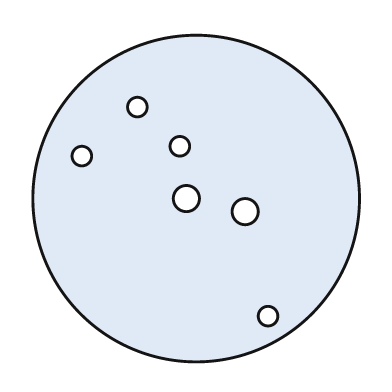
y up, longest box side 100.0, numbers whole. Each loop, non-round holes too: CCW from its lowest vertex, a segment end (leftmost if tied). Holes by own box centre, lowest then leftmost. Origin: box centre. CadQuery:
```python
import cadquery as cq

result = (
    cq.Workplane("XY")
    .moveTo(0.0, 0.0)
    .circle(50.0)
    .moveTo(22.0, -36.0)
    .circle(3.0)
    .moveTo(15.0, -4.0)
    .circle(4.0)
    .moveTo(-3.0, 0.0)
    .circle(4.0)
    .moveTo(-35.0, 13.0)
    .circle(3.0)
    .moveTo(-5.0, 16.0)
    .circle(3.0)
    .moveTo(-18.0, 28.0)
    .circle(3.0)
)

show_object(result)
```